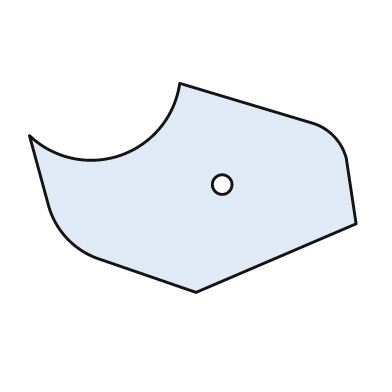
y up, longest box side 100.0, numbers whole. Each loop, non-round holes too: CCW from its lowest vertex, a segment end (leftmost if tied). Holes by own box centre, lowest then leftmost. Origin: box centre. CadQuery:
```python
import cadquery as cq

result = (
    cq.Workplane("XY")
    .moveTo(1.0, -32.0)
    .lineTo(50.0, -11.0)
    .lineTo(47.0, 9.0)
    .threePointArc((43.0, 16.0), (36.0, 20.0))
    .lineTo(-4.0, 32.0)
    .threePointArc((-22.0, 10.0), (-50.0, 16.0))
    .lineTo(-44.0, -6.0)
    .threePointArc((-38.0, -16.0), (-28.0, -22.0))
    .close()
    .moveTo(9.0, 1.0)
    .circle(3.0)
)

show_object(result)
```